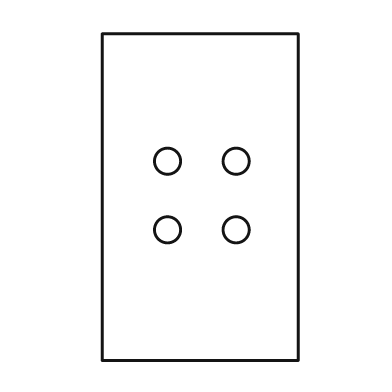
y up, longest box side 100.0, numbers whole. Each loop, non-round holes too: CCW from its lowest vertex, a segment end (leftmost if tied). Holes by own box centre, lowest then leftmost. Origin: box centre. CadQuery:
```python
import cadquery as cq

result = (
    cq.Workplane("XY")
    .moveTo(-30.0, -50.0)
    .lineTo(30.0, -50.0)
    .lineTo(30.0, 50.0)
    .lineTo(-30.0, 50.0)
    .close()
    .moveTo(-10.0, -10.0)
    .circle(4.0)
    .moveTo(11.0, -10.0)
    .circle(4.0)
    .moveTo(-10.0, 11.0)
    .circle(4.0)
    .moveTo(11.0, 11.0)
    .circle(4.0)
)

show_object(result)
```